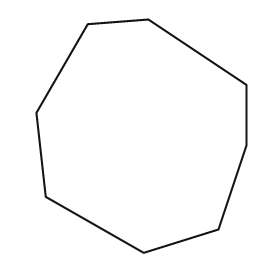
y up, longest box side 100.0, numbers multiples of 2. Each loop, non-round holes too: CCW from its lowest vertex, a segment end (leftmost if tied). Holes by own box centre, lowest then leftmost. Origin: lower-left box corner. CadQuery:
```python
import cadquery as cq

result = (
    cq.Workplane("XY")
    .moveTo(46.0, 0.0)
    .lineTo(78.0, 10.0)
    .lineTo(90.0, 46.0)
    .lineTo(90.0, 72.0)
    .lineTo(48.0, 100.0)
    .lineTo(22.0, 98.0)
    .lineTo(0.0, 60.0)
    .lineTo(4.0, 24.0)
    .close()
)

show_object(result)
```